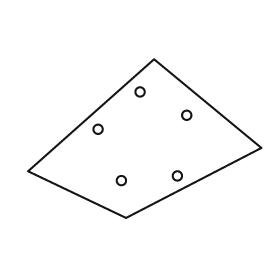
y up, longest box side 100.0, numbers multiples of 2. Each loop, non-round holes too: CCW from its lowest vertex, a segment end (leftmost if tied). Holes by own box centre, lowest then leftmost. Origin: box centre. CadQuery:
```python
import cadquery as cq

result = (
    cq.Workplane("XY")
    .moveTo(-8.0, -34.0)
    .lineTo(50.0, -4.0)
    .lineTo(4.0, 34.0)
    .lineTo(-50.0, -14.0)
    .close()
    .moveTo(-10.0, -18.0)
    .circle(2.0)
    .moveTo(14.0, -16.0)
    .circle(2.0)
    .moveTo(-20.0, 4.0)
    .circle(2.0)
    .moveTo(18.0, 10.0)
    .circle(2.0)
    .moveTo(-2.0, 20.0)
    .circle(2.0)
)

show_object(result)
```